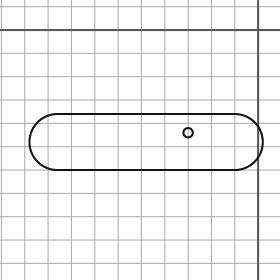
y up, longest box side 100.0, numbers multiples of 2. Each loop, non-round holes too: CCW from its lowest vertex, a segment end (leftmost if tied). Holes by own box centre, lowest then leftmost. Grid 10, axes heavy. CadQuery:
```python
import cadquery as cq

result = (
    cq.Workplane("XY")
    .moveTo(-86.0, -60.0)
    .lineTo(-10.0, -60.0)
    .threePointArc((2.0, -48.0), (-10.0, -36.0))
    .lineTo(-86.0, -36.0)
    .threePointArc((-98.0, -48.0), (-86.0, -60.0))
    .close()
    .moveTo(-30.0, -44.0)
    .circle(2.0)
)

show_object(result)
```